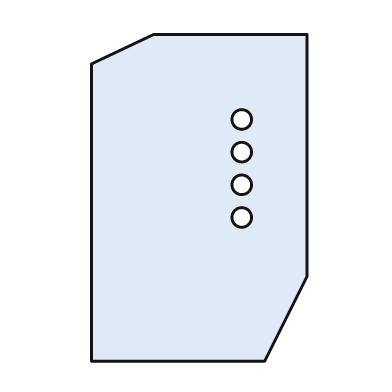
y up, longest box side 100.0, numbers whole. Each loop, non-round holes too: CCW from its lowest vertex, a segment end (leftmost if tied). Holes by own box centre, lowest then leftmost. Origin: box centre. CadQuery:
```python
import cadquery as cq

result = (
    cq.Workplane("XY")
    .moveTo(-33.0, -50.0)
    .lineTo(20.0, -50.0)
    .lineTo(33.0, -24.0)
    .lineTo(33.0, 50.0)
    .lineTo(-14.0, 50.0)
    .lineTo(-33.0, 41.0)
    .close()
    .moveTo(13.0, -6.0)
    .circle(3.0)
    .moveTo(13.0, 4.0)
    .circle(3.0)
    .moveTo(13.0, 14.0)
    .circle(3.0)
    .moveTo(13.0, 24.0)
    .circle(3.0)
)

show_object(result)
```